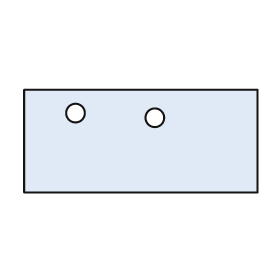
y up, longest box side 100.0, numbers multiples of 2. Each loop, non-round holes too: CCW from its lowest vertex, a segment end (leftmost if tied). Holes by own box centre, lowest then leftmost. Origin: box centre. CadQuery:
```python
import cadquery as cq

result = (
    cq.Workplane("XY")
    .moveTo(-50.0, -22.0)
    .lineTo(50.0, -22.0)
    .lineTo(50.0, 22.0)
    .lineTo(-50.0, 22.0)
    .close()
    .moveTo(6.0, 10.0)
    .circle(4.0)
    .moveTo(-28.0, 12.0)
    .circle(4.0)
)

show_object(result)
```